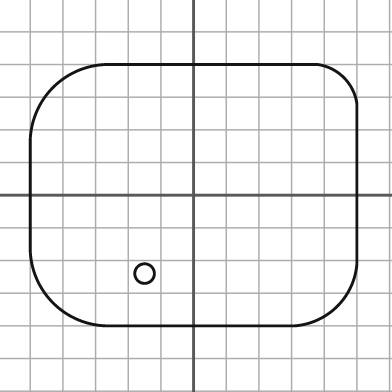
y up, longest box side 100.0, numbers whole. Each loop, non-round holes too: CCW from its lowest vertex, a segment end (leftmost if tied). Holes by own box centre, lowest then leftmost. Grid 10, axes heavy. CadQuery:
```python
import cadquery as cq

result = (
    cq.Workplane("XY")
    .moveTo(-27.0, -40.0)
    .lineTo(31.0, -40.0)
    .threePointArc((44.0, -34.0), (50.0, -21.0))
    .lineTo(50.0, 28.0)
    .threePointArc((46.0, 36.0), (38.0, 40.0))
    .lineTo(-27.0, 40.0)
    .threePointArc((-43.0, 33.0), (-50.0, 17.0))
    .lineTo(-50.0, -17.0)
    .threePointArc((-43.0, -33.0), (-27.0, -40.0))
    .close()
    .moveTo(-15.0, -24.0)
    .circle(3.0)
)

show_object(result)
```